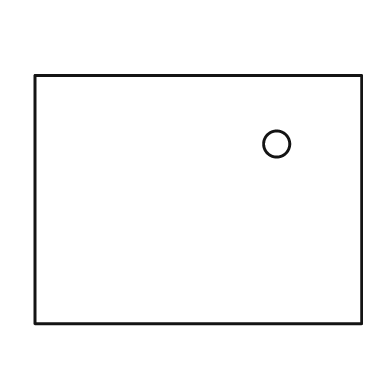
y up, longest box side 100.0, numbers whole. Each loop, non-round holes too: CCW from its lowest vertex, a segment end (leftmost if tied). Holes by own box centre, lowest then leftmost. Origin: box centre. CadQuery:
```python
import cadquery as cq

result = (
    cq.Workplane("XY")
    .moveTo(-50.0, -38.0)
    .lineTo(50.0, -38.0)
    .lineTo(50.0, 38.0)
    .lineTo(-50.0, 38.0)
    .close()
    .moveTo(24.0, 17.0)
    .circle(4.0)
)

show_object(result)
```